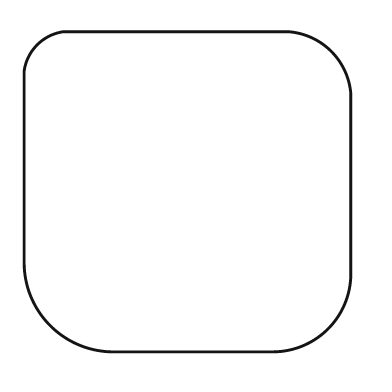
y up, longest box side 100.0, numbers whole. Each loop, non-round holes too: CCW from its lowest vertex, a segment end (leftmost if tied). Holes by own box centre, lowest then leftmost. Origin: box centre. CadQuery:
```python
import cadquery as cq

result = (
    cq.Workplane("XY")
    .moveTo(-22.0, -49.0)
    .lineTo(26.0, -49.0)
    .threePointArc((43.0, -42.0), (50.0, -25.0))
    .lineTo(50.0, 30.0)
    .threePointArc((44.0, 43.0), (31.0, 49.0))
    .lineTo(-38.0, 49.0)
    .threePointArc((-46.0, 45.0), (-50.0, 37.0))
    .lineTo(-50.0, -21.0)
    .threePointArc((-42.0, -41.0), (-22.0, -49.0))
    .close()
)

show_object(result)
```